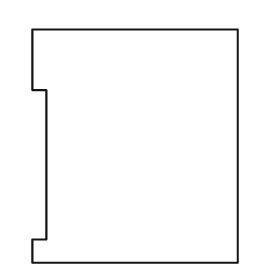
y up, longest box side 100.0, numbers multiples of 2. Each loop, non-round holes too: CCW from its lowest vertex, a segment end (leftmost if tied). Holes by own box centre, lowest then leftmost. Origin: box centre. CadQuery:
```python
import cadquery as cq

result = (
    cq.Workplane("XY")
    .moveTo(-44.0, -50.0)
    .lineTo(44.0, -50.0)
    .lineTo(44.0, 50.0)
    .lineTo(-44.0, 50.0)
    .lineTo(-44.0, 24.0)
    .lineTo(-38.0, 24.0)
    .lineTo(-38.0, -40.0)
    .lineTo(-44.0, -40.0)
    .close()
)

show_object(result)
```